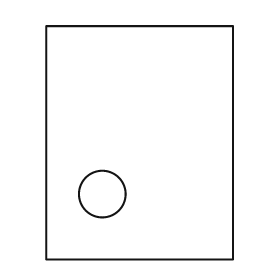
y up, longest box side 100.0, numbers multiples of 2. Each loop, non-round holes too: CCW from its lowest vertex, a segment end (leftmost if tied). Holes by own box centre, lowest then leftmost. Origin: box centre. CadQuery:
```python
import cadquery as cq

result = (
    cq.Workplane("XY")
    .moveTo(-40.0, -50.0)
    .lineTo(40.0, -50.0)
    .lineTo(40.0, 50.0)
    .lineTo(-40.0, 50.0)
    .close()
    .moveTo(-16.0, -22.0)
    .circle(10.0)
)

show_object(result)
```